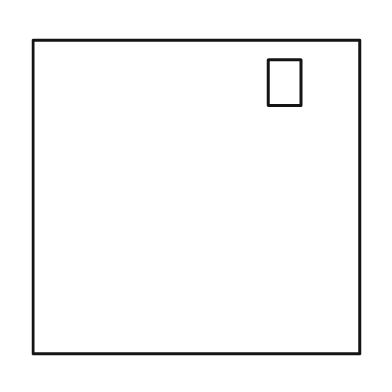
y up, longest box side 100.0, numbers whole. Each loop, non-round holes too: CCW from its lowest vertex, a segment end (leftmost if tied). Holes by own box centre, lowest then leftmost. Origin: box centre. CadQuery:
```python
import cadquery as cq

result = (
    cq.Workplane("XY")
    .moveTo(-50.0, -48.0)
    .lineTo(50.0, -48.0)
    .lineTo(50.0, 48.0)
    .lineTo(-50.0, 48.0)
    .close()
    .moveTo(22.0, 28.0)
    .lineTo(32.0, 28.0)
    .lineTo(32.0, 42.0)
    .lineTo(22.0, 42.0)
    .close()
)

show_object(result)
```